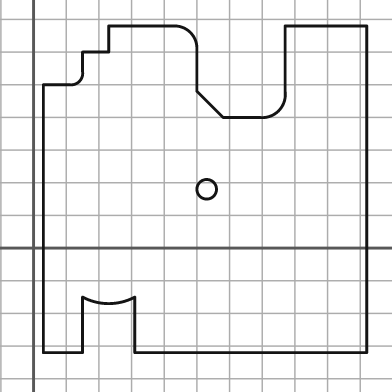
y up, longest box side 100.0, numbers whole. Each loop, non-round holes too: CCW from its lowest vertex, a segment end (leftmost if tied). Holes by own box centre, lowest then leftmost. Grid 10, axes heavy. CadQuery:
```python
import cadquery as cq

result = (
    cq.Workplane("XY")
    .moveTo(3.0, -32.0)
    .lineTo(15.0, -32.0)
    .lineTo(15.0, -15.0)
    .threePointArc((23.0, -17.0), (31.0, -15.0))
    .lineTo(31.0, -32.0)
    .lineTo(102.0, -32.0)
    .lineTo(102.0, 68.0)
    .lineTo(77.0, 68.0)
    .lineTo(77.0, 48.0)
    .threePointArc((75.0, 42.0), (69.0, 40.0))
    .lineTo(58.0, 40.0)
    .lineTo(50.0, 48.0)
    .lineTo(50.0, 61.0)
    .threePointArc((48.0, 66.0), (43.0, 68.0))
    .lineTo(23.0, 68.0)
    .lineTo(23.0, 60.0)
    .lineTo(15.0, 60.0)
    .lineTo(15.0, 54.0)
    .threePointArc((14.0, 51.0), (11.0, 50.0))
    .lineTo(3.0, 50.0)
    .close()
    .moveTo(53.0, 18.0)
    .circle(3.0)
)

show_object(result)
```